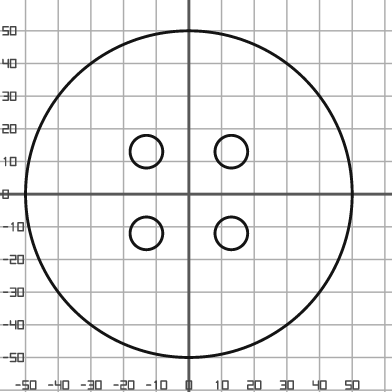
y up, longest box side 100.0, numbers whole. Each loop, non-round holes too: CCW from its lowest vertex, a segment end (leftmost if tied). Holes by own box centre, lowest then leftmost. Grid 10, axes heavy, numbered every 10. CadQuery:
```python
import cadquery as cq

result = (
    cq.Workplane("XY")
    .moveTo(0.0, 0.0)
    .circle(50.0)
    .moveTo(-13.0, -12.0)
    .circle(5.0)
    .moveTo(13.0, -12.0)
    .circle(5.0)
    .moveTo(-13.0, 13.0)
    .circle(5.0)
    .moveTo(13.0, 13.0)
    .circle(5.0)
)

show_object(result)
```